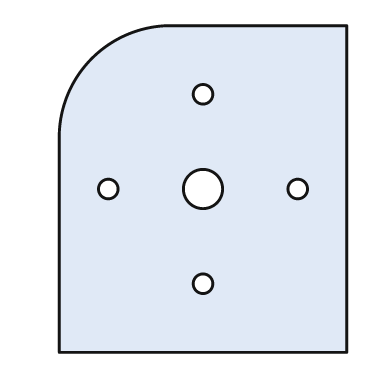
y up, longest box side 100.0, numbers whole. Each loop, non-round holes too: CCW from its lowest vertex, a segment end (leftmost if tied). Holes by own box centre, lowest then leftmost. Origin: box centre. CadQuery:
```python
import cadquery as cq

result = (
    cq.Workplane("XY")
    .moveTo(-44.0, -50.0)
    .lineTo(44.0, -50.0)
    .lineTo(44.0, 50.0)
    .lineTo(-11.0, 50.0)
    .threePointArc((-34.0, 40.0), (-44.0, 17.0))
    .close()
    .moveTo(0.0, -29.0)
    .circle(3.0)
    .moveTo(-29.0, 0.0)
    .circle(3.0)
    .moveTo(0.0, 0.0)
    .circle(6.0)
    .moveTo(29.0, 0.0)
    .circle(3.0)
    .moveTo(0.0, 29.0)
    .circle(3.0)
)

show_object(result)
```